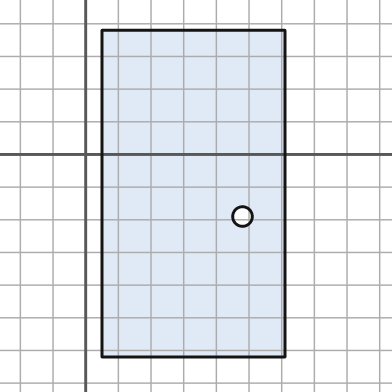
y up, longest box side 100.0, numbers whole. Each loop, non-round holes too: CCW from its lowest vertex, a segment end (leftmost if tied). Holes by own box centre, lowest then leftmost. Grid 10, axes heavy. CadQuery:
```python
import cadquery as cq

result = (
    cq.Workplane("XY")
    .moveTo(5.0, -62.0)
    .lineTo(61.0, -62.0)
    .lineTo(61.0, 38.0)
    .lineTo(5.0, 38.0)
    .close()
    .moveTo(48.0, -19.0)
    .circle(3.0)
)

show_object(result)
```